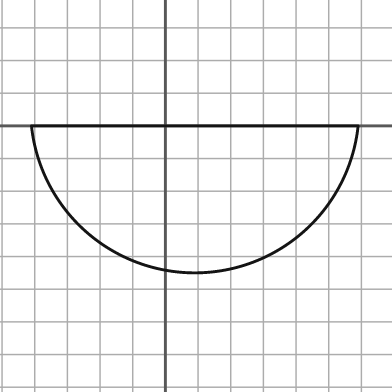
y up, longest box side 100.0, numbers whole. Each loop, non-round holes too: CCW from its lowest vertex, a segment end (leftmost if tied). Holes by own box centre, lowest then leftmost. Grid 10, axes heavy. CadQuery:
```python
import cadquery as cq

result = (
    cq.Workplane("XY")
    .moveTo(-41.0, 0.0)
    .threePointArc((9.0, -45.0), (59.0, 0.0))
    .close()
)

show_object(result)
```